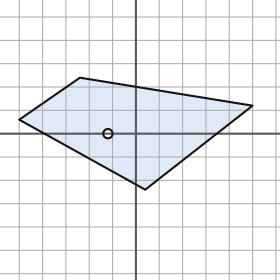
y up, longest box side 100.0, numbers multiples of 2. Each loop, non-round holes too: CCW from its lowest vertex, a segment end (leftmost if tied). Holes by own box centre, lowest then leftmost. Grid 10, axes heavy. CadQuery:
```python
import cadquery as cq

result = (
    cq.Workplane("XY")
    .moveTo(4.0, -24.0)
    .lineTo(50.0, 12.0)
    .lineTo(-24.0, 24.0)
    .lineTo(-50.0, 6.0)
    .close()
    .moveTo(-12.0, 0.0)
    .circle(2.0)
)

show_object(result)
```